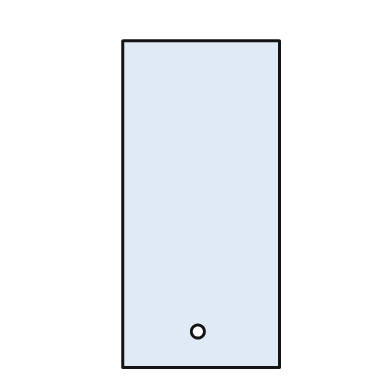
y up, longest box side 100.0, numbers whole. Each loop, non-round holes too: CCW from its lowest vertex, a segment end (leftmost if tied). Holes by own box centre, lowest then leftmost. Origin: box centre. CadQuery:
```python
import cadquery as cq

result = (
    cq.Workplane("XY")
    .moveTo(-24.0, -50.0)
    .lineTo(24.0, -50.0)
    .lineTo(24.0, 50.0)
    .lineTo(-24.0, 50.0)
    .close()
    .moveTo(-1.0, -39.0)
    .circle(2.0)
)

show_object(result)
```